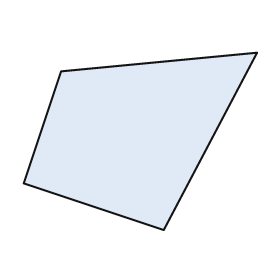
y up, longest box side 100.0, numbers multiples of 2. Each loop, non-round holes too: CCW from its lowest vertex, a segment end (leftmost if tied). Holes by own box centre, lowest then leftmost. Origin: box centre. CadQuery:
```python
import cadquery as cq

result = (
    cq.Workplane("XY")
    .moveTo(10.0, -38.0)
    .lineTo(50.0, 38.0)
    .lineTo(-34.0, 30.0)
    .lineTo(-50.0, -18.0)
    .close()
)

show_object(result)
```